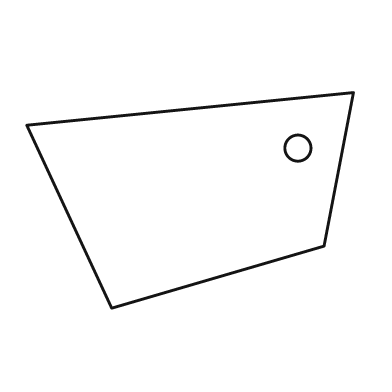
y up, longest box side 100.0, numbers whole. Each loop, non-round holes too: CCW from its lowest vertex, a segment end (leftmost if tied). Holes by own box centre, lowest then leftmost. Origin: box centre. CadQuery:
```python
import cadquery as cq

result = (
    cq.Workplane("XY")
    .moveTo(-24.0, -33.0)
    .lineTo(41.0, -14.0)
    .lineTo(50.0, 33.0)
    .lineTo(-50.0, 23.0)
    .close()
    .moveTo(33.0, 16.0)
    .circle(4.0)
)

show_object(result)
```